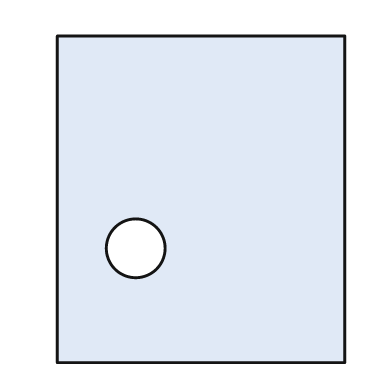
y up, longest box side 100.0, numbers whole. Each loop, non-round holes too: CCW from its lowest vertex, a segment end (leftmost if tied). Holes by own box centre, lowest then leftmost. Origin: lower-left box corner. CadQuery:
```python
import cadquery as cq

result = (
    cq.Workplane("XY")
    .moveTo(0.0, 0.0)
    .lineTo(88.0, 0.0)
    .lineTo(88.0, 100.0)
    .lineTo(0.0, 100.0)
    .close()
    .moveTo(24.0, 35.0)
    .circle(9.0)
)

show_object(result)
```